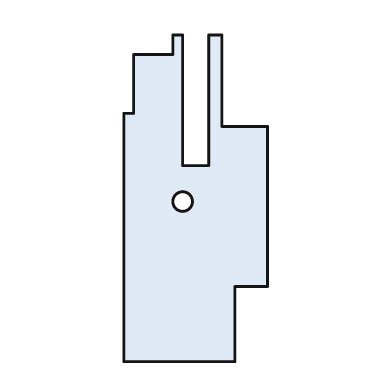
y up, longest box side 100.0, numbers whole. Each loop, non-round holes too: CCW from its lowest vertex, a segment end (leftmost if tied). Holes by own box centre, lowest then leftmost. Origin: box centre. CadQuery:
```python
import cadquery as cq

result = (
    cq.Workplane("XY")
    .moveTo(-22.0, -50.0)
    .lineTo(12.0, -50.0)
    .lineTo(12.0, -27.0)
    .lineTo(22.0, -27.0)
    .lineTo(22.0, 22.0)
    .lineTo(8.0, 22.0)
    .lineTo(8.0, 50.0)
    .lineTo(4.0, 50.0)
    .lineTo(4.0, 10.0)
    .lineTo(-4.0, 10.0)
    .lineTo(-4.0, 50.0)
    .lineTo(-7.0, 50.0)
    .lineTo(-7.0, 44.0)
    .lineTo(-19.0, 44.0)
    .lineTo(-19.0, 26.0)
    .lineTo(-22.0, 26.0)
    .close()
    .moveTo(-4.0, -1.0)
    .circle(3.0)
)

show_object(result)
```